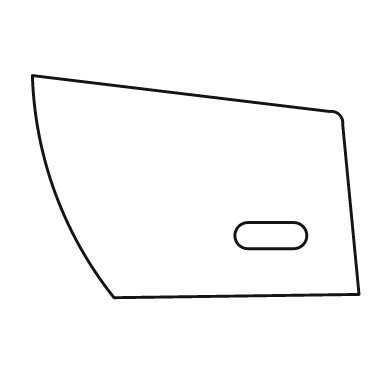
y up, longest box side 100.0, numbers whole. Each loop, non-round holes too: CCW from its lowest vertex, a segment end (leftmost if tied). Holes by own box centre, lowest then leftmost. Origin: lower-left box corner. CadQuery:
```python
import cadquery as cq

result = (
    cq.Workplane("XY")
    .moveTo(25.0, 0.0)
    .lineTo(100.0, 1.0)
    .lineTo(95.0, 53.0)
    .threePointArc((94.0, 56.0), (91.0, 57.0))
    .lineTo(0.0, 68.0)
    .threePointArc((7.0, 32.0), (25.0, 0.0))
    .close()
    .moveTo(66.0, 15.0)
    .lineTo(80.0, 15.0)
    .threePointArc((84.0, 19.0), (80.0, 23.0))
    .lineTo(66.0, 23.0)
    .threePointArc((62.0, 19.0), (66.0, 15.0))
    .close()
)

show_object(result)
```